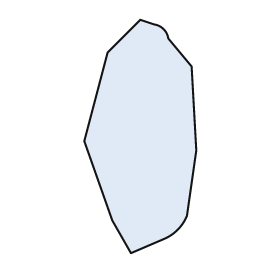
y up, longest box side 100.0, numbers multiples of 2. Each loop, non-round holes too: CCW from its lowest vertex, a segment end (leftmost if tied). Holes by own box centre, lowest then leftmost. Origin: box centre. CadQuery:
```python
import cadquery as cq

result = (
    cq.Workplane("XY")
    .moveTo(-4.0, -50.0)
    .lineTo(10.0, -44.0)
    .threePointArc((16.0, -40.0), (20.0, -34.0))
    .lineTo(24.0, -6.0)
    .lineTo(22.0, 30.0)
    .lineTo(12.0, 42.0)
    .threePointArc((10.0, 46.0), (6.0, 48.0))
    .lineTo(0.0, 50.0)
    .lineTo(-14.0, 36.0)
    .lineTo(-24.0, -2.0)
    .lineTo(-12.0, -36.0)
    .close()
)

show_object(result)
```